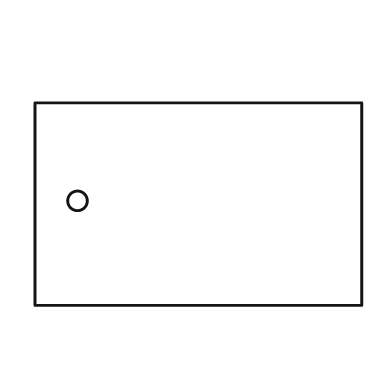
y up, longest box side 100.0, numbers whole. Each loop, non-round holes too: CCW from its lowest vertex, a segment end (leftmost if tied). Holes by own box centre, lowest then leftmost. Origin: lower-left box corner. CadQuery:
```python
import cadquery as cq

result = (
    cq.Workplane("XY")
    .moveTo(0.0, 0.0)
    .lineTo(100.0, 0.0)
    .lineTo(100.0, 62.0)
    .lineTo(0.0, 62.0)
    .close()
    .moveTo(13.0, 32.0)
    .circle(3.0)
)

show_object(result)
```